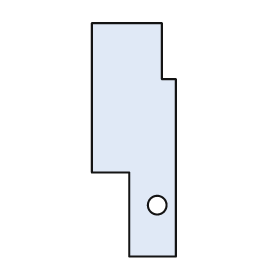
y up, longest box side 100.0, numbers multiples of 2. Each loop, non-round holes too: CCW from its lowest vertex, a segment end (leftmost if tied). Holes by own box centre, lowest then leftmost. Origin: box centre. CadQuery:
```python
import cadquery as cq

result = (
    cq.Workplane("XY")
    .moveTo(-2.0, -50.0)
    .lineTo(18.0, -50.0)
    .lineTo(18.0, 26.0)
    .lineTo(12.0, 26.0)
    .lineTo(12.0, 50.0)
    .lineTo(-18.0, 50.0)
    .lineTo(-18.0, -14.0)
    .lineTo(-2.0, -14.0)
    .close()
    .moveTo(10.0, -28.0)
    .circle(4.0)
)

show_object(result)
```